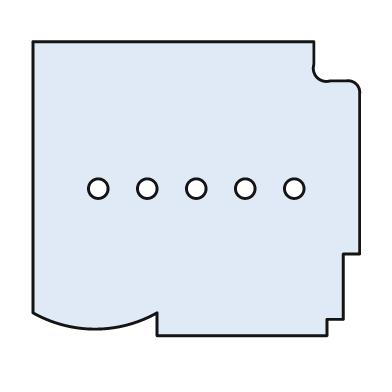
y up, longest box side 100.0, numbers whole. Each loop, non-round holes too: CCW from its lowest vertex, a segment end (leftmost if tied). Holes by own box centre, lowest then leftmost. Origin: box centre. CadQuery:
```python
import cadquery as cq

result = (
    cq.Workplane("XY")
    .moveTo(-12.0, -45.0)
    .lineTo(40.0, -45.0)
    .lineTo(40.0, -40.0)
    .lineTo(45.0, -40.0)
    .lineTo(45.0, -20.0)
    .lineTo(50.0, -20.0)
    .lineTo(50.0, 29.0)
    .threePointArc((49.0, 32.0), (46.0, 33.0))
    .lineTo(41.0, 33.0)
    .threePointArc((37.0, 34.0), (36.0, 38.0))
    .lineTo(36.0, 45.0)
    .lineTo(-50.0, 45.0)
    .lineTo(-50.0, -38.0)
    .threePointArc((-31.0, -43.0), (-12.0, -38.0))
    .close()
    .moveTo(-30.0, 0.0)
    .circle(3.0)
    .moveTo(-15.0, 0.0)
    .circle(3.0)
    .moveTo(0.0, 0.0)
    .circle(3.0)
    .moveTo(15.0, 0.0)
    .circle(3.0)
    .moveTo(30.0, 0.0)
    .circle(3.0)
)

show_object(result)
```